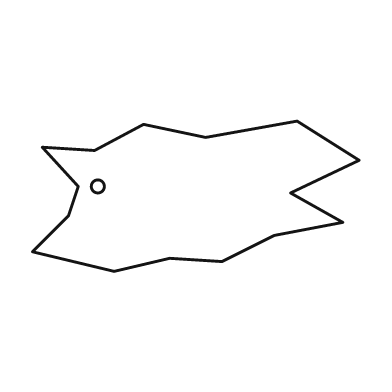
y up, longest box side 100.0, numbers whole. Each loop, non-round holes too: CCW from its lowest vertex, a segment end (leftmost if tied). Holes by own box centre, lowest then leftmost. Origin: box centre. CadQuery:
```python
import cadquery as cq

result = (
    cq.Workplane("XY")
    .moveTo(-25.0, -23.0)
    .lineTo(-8.0, -19.0)
    .lineTo(8.0, -20.0)
    .lineTo(24.0, -12.0)
    .lineTo(45.0, -8.0)
    .lineTo(29.0, 1.0)
    .lineTo(50.0, 11.0)
    .lineTo(31.0, 23.0)
    .lineTo(3.0, 18.0)
    .lineTo(-16.0, 22.0)
    .lineTo(-31.0, 14.0)
    .lineTo(-47.0, 15.0)
    .lineTo(-36.0, 3.0)
    .lineTo(-39.0, -6.0)
    .lineTo(-50.0, -17.0)
    .close()
    .moveTo(-30.0, 3.0)
    .circle(2.0)
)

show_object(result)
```